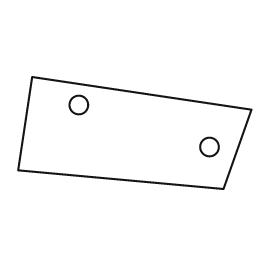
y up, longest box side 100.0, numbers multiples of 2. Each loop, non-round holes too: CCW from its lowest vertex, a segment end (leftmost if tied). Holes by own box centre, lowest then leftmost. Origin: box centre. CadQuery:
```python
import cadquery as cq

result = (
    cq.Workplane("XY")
    .moveTo(38.0, -24.0)
    .lineTo(50.0, 10.0)
    .lineTo(-44.0, 24.0)
    .lineTo(-50.0, -16.0)
    .close()
    .moveTo(32.0, -6.0)
    .circle(4.0)
    .moveTo(-24.0, 12.0)
    .circle(4.0)
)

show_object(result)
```